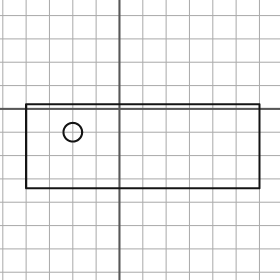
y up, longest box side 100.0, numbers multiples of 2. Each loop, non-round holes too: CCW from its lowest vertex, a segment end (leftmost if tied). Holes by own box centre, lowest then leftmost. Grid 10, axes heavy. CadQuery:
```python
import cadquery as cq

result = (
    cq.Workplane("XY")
    .moveTo(-40.0, -34.0)
    .lineTo(60.0, -34.0)
    .lineTo(60.0, 2.0)
    .lineTo(-40.0, 2.0)
    .close()
    .moveTo(-20.0, -10.0)
    .circle(4.0)
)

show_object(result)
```